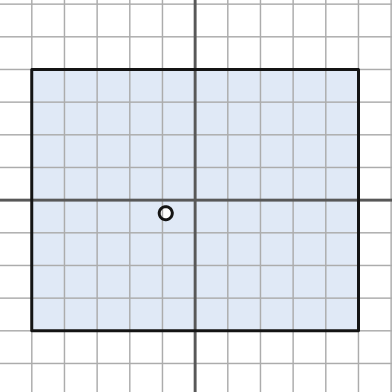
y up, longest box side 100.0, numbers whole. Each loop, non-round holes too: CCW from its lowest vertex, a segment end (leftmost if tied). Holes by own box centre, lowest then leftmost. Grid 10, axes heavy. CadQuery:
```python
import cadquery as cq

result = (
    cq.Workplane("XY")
    .moveTo(-50.0, -40.0)
    .lineTo(50.0, -40.0)
    .lineTo(50.0, 40.0)
    .lineTo(-50.0, 40.0)
    .close()
    .moveTo(-9.0, -4.0)
    .circle(2.0)
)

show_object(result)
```